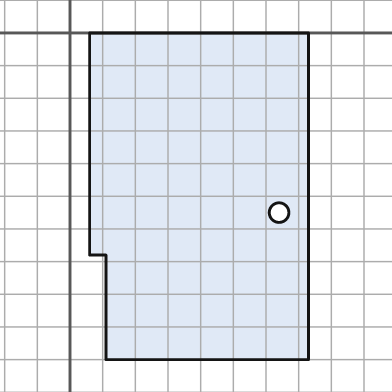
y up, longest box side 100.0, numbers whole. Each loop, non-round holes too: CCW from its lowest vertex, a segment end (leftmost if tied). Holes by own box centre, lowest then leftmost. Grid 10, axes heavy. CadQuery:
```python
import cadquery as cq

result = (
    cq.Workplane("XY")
    .moveTo(11.0, -100.0)
    .lineTo(73.0, -100.0)
    .lineTo(73.0, 0.0)
    .lineTo(6.0, 0.0)
    .lineTo(6.0, -68.0)
    .lineTo(11.0, -68.0)
    .close()
    .moveTo(64.0, -55.0)
    .circle(3.0)
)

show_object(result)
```